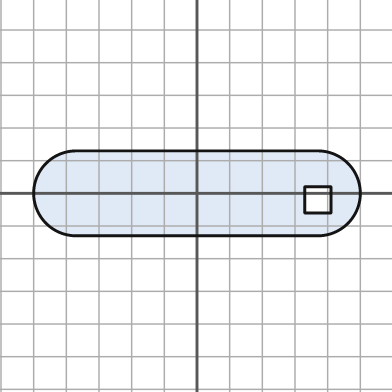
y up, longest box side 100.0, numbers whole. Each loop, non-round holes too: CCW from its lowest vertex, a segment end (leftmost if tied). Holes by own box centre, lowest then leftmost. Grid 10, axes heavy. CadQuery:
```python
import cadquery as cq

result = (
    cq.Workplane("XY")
    .moveTo(-37.0, -13.0)
    .lineTo(37.0, -13.0)
    .threePointArc((50.0, 0.0), (37.0, 13.0))
    .lineTo(-37.0, 13.0)
    .threePointArc((-50.0, 0.0), (-37.0, -13.0))
    .close()
    .moveTo(33.0, -6.0)
    .lineTo(41.0, -6.0)
    .lineTo(41.0, 2.0)
    .lineTo(33.0, 2.0)
    .close()
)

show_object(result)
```